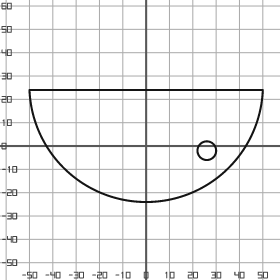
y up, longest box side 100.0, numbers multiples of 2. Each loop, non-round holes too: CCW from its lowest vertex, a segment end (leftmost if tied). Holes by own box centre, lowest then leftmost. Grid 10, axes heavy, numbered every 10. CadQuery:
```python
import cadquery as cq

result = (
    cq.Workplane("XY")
    .moveTo(-50.0, 24.0)
    .threePointArc((0.0, -24.0), (50.0, 24.0))
    .close()
    .moveTo(26.0, -2.0)
    .circle(4.0)
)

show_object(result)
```